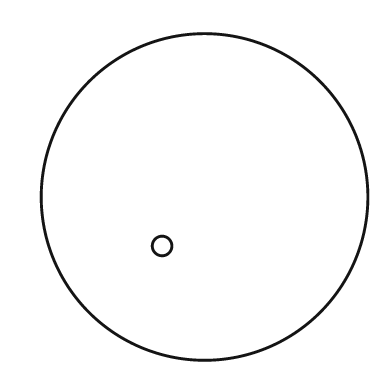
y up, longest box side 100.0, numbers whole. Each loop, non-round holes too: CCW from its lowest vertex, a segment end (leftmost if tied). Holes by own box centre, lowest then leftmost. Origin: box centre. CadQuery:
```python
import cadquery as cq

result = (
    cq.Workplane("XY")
    .moveTo(0.0, 0.0)
    .circle(50.0)
    .moveTo(-13.0, -15.0)
    .circle(3.0)
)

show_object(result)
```